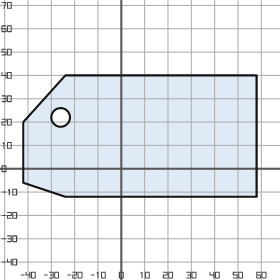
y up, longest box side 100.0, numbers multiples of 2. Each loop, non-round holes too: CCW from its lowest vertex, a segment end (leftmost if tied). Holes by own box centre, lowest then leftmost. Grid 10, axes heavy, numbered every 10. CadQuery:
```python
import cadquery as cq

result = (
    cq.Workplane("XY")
    .moveTo(-24.0, -12.0)
    .lineTo(58.0, -12.0)
    .lineTo(58.0, 40.0)
    .lineTo(-24.0, 40.0)
    .lineTo(-42.0, 20.0)
    .lineTo(-42.0, -6.0)
    .close()
    .moveTo(-26.0, 22.0)
    .circle(4.0)
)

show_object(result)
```